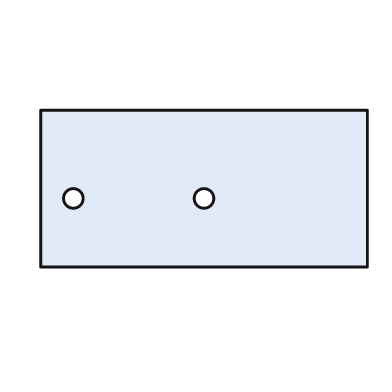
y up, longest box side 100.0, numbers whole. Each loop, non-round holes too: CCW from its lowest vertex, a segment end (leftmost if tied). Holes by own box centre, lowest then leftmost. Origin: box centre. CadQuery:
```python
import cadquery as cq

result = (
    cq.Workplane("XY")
    .moveTo(-50.0, -24.0)
    .lineTo(50.0, -24.0)
    .lineTo(50.0, 24.0)
    .lineTo(-50.0, 24.0)
    .close()
    .moveTo(-40.0, -3.0)
    .circle(3.0)
    .moveTo(0.0, -3.0)
    .circle(3.0)
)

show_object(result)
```